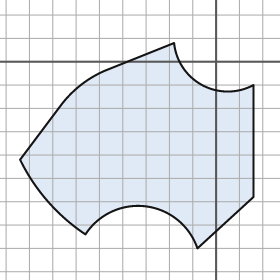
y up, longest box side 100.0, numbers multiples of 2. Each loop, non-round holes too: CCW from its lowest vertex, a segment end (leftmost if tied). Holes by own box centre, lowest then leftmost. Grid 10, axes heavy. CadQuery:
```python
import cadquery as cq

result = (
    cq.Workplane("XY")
    .moveTo(-8.0, -80.0)
    .lineTo(16.0, -58.0)
    .lineTo(16.0, -10.0)
    .threePointArc((-6.0, -10.0), (-18.0, 8.0))
    .lineTo(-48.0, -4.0)
    .threePointArc((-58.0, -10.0), (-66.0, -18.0))
    .lineTo(-84.0, -42.0)
    .threePointArc((-72.0, -60.0), (-56.0, -74.0))
    .threePointArc((-30.0, -62.0), (-8.0, -80.0))
    .close()
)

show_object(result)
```